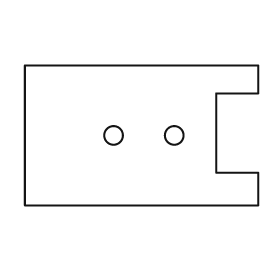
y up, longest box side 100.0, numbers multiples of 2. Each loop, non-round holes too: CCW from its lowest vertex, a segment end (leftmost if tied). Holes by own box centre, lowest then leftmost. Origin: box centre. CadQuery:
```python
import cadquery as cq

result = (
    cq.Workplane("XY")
    .moveTo(-50.0, -30.0)
    .lineTo(50.0, -30.0)
    .lineTo(50.0, -16.0)
    .lineTo(32.0, -16.0)
    .lineTo(32.0, 18.0)
    .lineTo(50.0, 18.0)
    .lineTo(50.0, 30.0)
    .lineTo(-50.0, 30.0)
    .close()
    .moveTo(-12.0, 0.0)
    .circle(4.0)
    .moveTo(14.0, 0.0)
    .circle(4.0)
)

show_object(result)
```